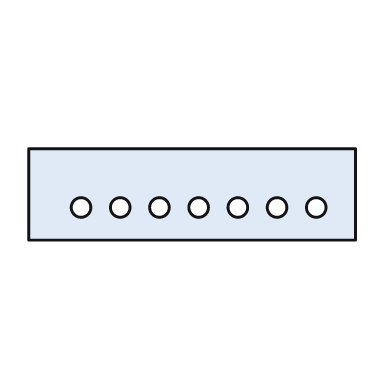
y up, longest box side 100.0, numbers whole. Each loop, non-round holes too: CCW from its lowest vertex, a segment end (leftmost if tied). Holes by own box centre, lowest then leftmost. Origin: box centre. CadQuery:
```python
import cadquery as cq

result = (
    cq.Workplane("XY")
    .moveTo(-50.0, -14.0)
    .lineTo(50.0, -14.0)
    .lineTo(50.0, 14.0)
    .lineTo(-50.0, 14.0)
    .close()
    .moveTo(-34.0, -4.0)
    .circle(3.0)
    .moveTo(-22.0, -4.0)
    .circle(3.0)
    .moveTo(-10.0, -4.0)
    .circle(3.0)
    .moveTo(2.0, -4.0)
    .circle(3.0)
    .moveTo(14.0, -4.0)
    .circle(3.0)
    .moveTo(26.0, -4.0)
    .circle(3.0)
    .moveTo(38.0, -4.0)
    .circle(3.0)
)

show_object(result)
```